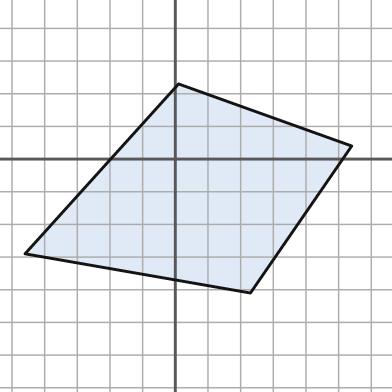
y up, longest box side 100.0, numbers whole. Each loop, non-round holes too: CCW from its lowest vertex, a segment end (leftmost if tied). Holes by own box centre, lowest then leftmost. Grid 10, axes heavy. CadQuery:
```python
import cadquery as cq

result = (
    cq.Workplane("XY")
    .moveTo(23.0, -41.0)
    .lineTo(54.0, 4.0)
    .lineTo(1.0, 23.0)
    .lineTo(-46.0, -29.0)
    .close()
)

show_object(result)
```